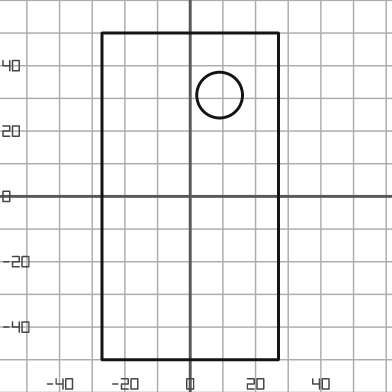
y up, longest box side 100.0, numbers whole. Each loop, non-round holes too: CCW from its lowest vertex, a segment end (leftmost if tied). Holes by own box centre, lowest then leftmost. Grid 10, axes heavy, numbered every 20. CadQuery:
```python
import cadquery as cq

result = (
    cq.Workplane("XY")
    .moveTo(-27.0, -50.0)
    .lineTo(27.0, -50.0)
    .lineTo(27.0, 50.0)
    .lineTo(-27.0, 50.0)
    .close()
    .moveTo(9.0, 31.0)
    .circle(7.0)
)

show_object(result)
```